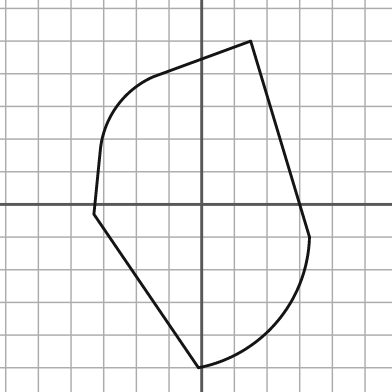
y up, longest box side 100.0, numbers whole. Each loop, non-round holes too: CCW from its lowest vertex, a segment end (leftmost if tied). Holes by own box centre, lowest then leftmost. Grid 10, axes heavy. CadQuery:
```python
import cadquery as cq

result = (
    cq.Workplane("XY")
    .moveTo(-1.0, -50.0)
    .threePointArc((23.0, -36.0), (33.0, -10.0))
    .lineTo(15.0, 50.0)
    .lineTo(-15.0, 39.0)
    .threePointArc((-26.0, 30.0), (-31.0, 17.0))
    .lineTo(-33.0, -3.0)
    .close()
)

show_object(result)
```